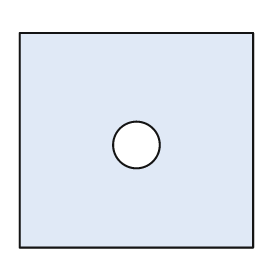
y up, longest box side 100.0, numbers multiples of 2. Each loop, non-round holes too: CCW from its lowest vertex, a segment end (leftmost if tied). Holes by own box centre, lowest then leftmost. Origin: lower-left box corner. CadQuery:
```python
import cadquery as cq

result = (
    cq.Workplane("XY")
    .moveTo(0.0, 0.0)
    .lineTo(100.0, 0.0)
    .lineTo(100.0, 92.0)
    .lineTo(0.0, 92.0)
    .close()
    .moveTo(50.0, 44.0)
    .circle(10.0)
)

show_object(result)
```